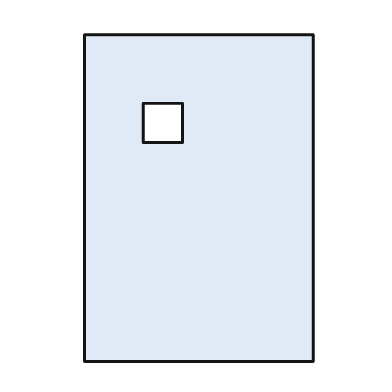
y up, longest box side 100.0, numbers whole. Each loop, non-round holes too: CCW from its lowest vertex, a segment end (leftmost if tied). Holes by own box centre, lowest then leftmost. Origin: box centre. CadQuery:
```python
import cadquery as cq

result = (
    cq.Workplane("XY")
    .moveTo(-35.0, -50.0)
    .lineTo(35.0, -50.0)
    .lineTo(35.0, 50.0)
    .lineTo(-35.0, 50.0)
    .close()
    .moveTo(-17.0, 17.0)
    .lineTo(-5.0, 17.0)
    .lineTo(-5.0, 29.0)
    .lineTo(-17.0, 29.0)
    .close()
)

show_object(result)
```